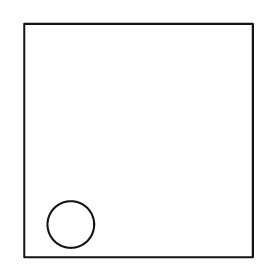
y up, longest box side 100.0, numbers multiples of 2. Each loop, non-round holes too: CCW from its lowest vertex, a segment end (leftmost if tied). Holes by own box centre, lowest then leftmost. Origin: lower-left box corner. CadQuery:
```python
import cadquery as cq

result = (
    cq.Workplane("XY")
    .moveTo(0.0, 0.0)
    .lineTo(98.0, 0.0)
    .lineTo(98.0, 100.0)
    .lineTo(0.0, 100.0)
    .close()
    .moveTo(20.0, 14.0)
    .circle(10.0)
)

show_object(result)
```